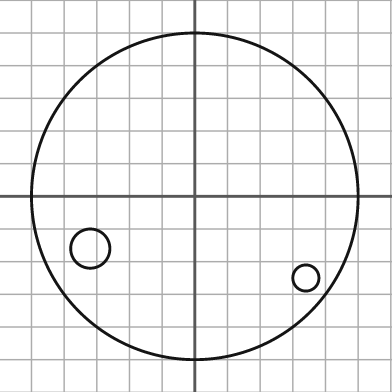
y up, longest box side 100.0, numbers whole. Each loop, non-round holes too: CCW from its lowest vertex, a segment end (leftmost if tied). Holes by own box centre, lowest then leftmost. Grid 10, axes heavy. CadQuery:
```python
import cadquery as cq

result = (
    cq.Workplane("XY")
    .moveTo(0.0, 0.0)
    .circle(50.0)
    .moveTo(34.0, -25.0)
    .circle(4.0)
    .moveTo(-32.0, -16.0)
    .circle(6.0)
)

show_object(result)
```